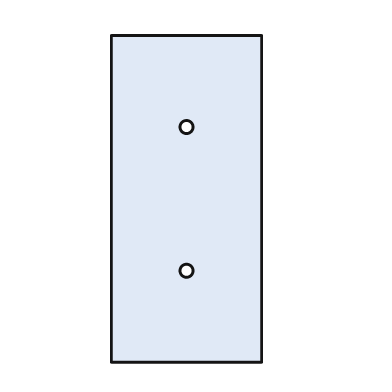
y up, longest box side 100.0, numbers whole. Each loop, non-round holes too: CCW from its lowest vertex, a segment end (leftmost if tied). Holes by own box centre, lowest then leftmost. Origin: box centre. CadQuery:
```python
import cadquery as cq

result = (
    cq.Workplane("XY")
    .moveTo(-23.0, -50.0)
    .lineTo(23.0, -50.0)
    .lineTo(23.0, 50.0)
    .lineTo(-23.0, 50.0)
    .close()
    .moveTo(0.0, -22.0)
    .circle(2.0)
    .moveTo(0.0, 22.0)
    .circle(2.0)
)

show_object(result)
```